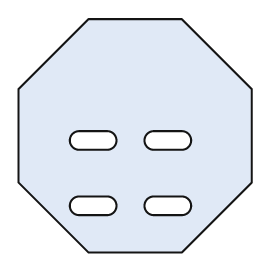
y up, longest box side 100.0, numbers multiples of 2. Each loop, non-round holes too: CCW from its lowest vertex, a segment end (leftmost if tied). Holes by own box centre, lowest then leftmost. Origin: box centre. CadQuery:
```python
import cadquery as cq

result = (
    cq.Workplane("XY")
    .moveTo(-20.0, -50.0)
    .lineTo(20.0, -50.0)
    .lineTo(50.0, -20.0)
    .lineTo(50.0, 20.0)
    .lineTo(20.0, 50.0)
    .lineTo(-20.0, 50.0)
    .lineTo(-50.0, 20.0)
    .lineTo(-50.0, -20.0)
    .close()
    .moveTo(-24.0, -34.0)
    .lineTo(-12.0, -34.0)
    .threePointArc((-8.0, -30.0), (-12.0, -26.0))
    .lineTo(-24.0, -26.0)
    .threePointArc((-28.0, -30.0), (-24.0, -34.0))
    .close()
    .moveTo(8.0, -34.0)
    .lineTo(20.0, -34.0)
    .threePointArc((24.0, -30.0), (20.0, -26.0))
    .lineTo(8.0, -26.0)
    .threePointArc((4.0, -30.0), (8.0, -34.0))
    .close()
    .moveTo(-24.0, -6.0)
    .lineTo(-12.0, -6.0)
    .threePointArc((-8.0, -2.0), (-12.0, 2.0))
    .lineTo(-24.0, 2.0)
    .threePointArc((-28.0, -2.0), (-24.0, -6.0))
    .close()
    .moveTo(8.0, -6.0)
    .lineTo(20.0, -6.0)
    .threePointArc((24.0, -2.0), (20.0, 2.0))
    .lineTo(8.0, 2.0)
    .threePointArc((4.0, -2.0), (8.0, -6.0))
    .close()
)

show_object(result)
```